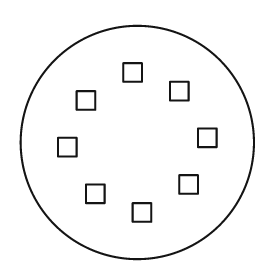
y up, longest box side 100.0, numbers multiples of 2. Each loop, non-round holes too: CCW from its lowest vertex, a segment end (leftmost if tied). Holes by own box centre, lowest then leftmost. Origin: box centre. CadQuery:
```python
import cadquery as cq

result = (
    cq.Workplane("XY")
    .moveTo(0.0, 0.0)
    .circle(50.0)
    .moveTo(-2.0, -34.0)
    .lineTo(6.0, -34.0)
    .lineTo(6.0, -26.0)
    .lineTo(-2.0, -26.0)
    .close()
    .moveTo(-22.0, -26.0)
    .lineTo(-14.0, -26.0)
    .lineTo(-14.0, -18.0)
    .lineTo(-22.0, -18.0)
    .close()
    .moveTo(18.0, -22.0)
    .lineTo(26.0, -22.0)
    .lineTo(26.0, -14.0)
    .lineTo(18.0, -14.0)
    .close()
    .moveTo(-34.0, -6.0)
    .lineTo(-26.0, -6.0)
    .lineTo(-26.0, 2.0)
    .lineTo(-34.0, 2.0)
    .close()
    .moveTo(26.0, -2.0)
    .lineTo(34.0, -2.0)
    .lineTo(34.0, 6.0)
    .lineTo(26.0, 6.0)
    .close()
    .moveTo(-26.0, 14.0)
    .lineTo(-18.0, 14.0)
    .lineTo(-18.0, 22.0)
    .lineTo(-26.0, 22.0)
    .close()
    .moveTo(14.0, 18.0)
    .lineTo(22.0, 18.0)
    .lineTo(22.0, 26.0)
    .lineTo(14.0, 26.0)
    .close()
    .moveTo(-6.0, 26.0)
    .lineTo(2.0, 26.0)
    .lineTo(2.0, 34.0)
    .lineTo(-6.0, 34.0)
    .close()
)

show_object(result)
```